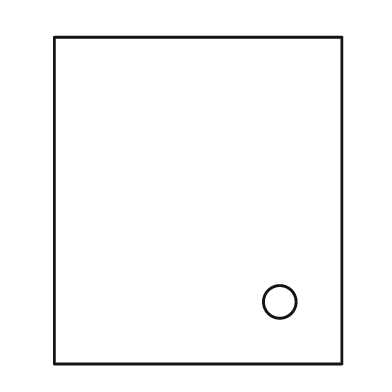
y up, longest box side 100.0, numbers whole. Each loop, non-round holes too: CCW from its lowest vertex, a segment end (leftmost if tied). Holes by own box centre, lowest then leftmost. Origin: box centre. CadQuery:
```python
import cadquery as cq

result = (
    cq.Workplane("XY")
    .moveTo(-44.0, -50.0)
    .lineTo(44.0, -50.0)
    .lineTo(44.0, 50.0)
    .lineTo(-44.0, 50.0)
    .close()
    .moveTo(25.0, -31.0)
    .circle(5.0)
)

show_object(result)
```